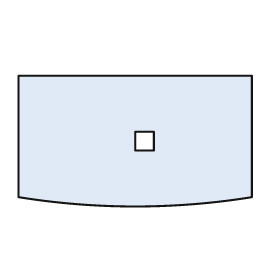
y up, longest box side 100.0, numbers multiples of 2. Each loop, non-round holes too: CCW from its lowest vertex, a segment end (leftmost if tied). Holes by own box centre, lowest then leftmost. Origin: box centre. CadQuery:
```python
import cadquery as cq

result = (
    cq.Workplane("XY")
    .moveTo(-50.0, -24.0)
    .threePointArc((0.0, -28.0), (50.0, -24.0))
    .lineTo(50.0, 28.0)
    .lineTo(-50.0, 28.0)
    .close()
    .moveTo(0.0, -4.0)
    .lineTo(8.0, -4.0)
    .lineTo(8.0, 4.0)
    .lineTo(0.0, 4.0)
    .close()
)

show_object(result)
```